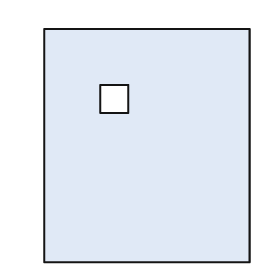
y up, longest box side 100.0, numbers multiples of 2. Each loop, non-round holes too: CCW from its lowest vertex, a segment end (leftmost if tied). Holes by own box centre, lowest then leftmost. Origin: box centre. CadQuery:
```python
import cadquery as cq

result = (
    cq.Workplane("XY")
    .moveTo(-44.0, -50.0)
    .lineTo(44.0, -50.0)
    .lineTo(44.0, 50.0)
    .lineTo(-44.0, 50.0)
    .close()
    .moveTo(-20.0, 14.0)
    .lineTo(-8.0, 14.0)
    .lineTo(-8.0, 26.0)
    .lineTo(-20.0, 26.0)
    .close()
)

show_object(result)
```